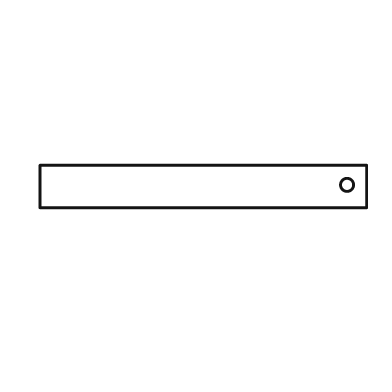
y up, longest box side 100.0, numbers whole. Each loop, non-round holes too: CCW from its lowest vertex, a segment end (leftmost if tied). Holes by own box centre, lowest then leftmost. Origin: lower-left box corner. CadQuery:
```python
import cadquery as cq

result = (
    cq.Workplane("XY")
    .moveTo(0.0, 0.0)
    .lineTo(100.0, 0.0)
    .lineTo(100.0, 13.0)
    .lineTo(0.0, 13.0)
    .close()
    .moveTo(94.0, 7.0)
    .circle(2.0)
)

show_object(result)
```